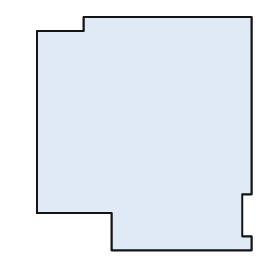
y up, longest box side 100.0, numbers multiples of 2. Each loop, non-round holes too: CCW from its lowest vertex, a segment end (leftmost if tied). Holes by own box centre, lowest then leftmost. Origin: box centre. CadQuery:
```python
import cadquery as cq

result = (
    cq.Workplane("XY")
    .moveTo(-14.0, -50.0)
    .lineTo(46.0, -50.0)
    .lineTo(46.0, -44.0)
    .lineTo(42.0, -44.0)
    .lineTo(42.0, -26.0)
    .lineTo(46.0, -26.0)
    .lineTo(46.0, 50.0)
    .lineTo(-26.0, 50.0)
    .lineTo(-26.0, 44.0)
    .lineTo(-46.0, 44.0)
    .lineTo(-46.0, -34.0)
    .lineTo(-14.0, -34.0)
    .close()
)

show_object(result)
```